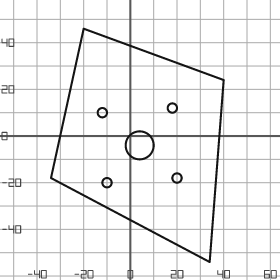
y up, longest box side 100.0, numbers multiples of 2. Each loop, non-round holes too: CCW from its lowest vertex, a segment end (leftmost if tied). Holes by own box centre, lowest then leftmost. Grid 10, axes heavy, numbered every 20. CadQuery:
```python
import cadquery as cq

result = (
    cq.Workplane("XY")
    .moveTo(34.0, -54.0)
    .lineTo(40.0, 24.0)
    .lineTo(-20.0, 46.0)
    .lineTo(-34.0, -18.0)
    .close()
    .moveTo(-10.0, -20.0)
    .circle(2.0)
    .moveTo(20.0, -18.0)
    .circle(2.0)
    .moveTo(4.0, -4.0)
    .circle(6.0)
    .moveTo(-12.0, 10.0)
    .circle(2.0)
    .moveTo(18.0, 12.0)
    .circle(2.0)
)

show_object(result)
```